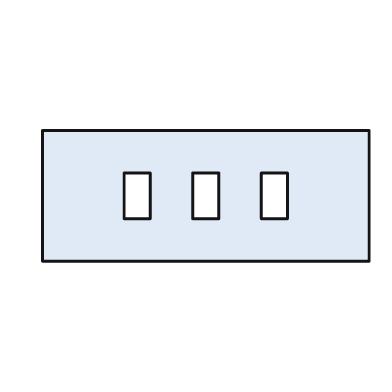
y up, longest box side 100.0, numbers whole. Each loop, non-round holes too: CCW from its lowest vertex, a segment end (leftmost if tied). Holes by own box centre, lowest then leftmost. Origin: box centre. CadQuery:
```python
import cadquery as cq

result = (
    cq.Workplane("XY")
    .moveTo(-50.0, -20.0)
    .lineTo(50.0, -20.0)
    .lineTo(50.0, 20.0)
    .lineTo(-50.0, 20.0)
    .close()
    .moveTo(-25.0, -7.0)
    .lineTo(-17.0, -7.0)
    .lineTo(-17.0, 7.0)
    .lineTo(-25.0, 7.0)
    .close()
    .moveTo(-4.0, -7.0)
    .lineTo(4.0, -7.0)
    .lineTo(4.0, 7.0)
    .lineTo(-4.0, 7.0)
    .close()
    .moveTo(17.0, -7.0)
    .lineTo(25.0, -7.0)
    .lineTo(25.0, 7.0)
    .lineTo(17.0, 7.0)
    .close()
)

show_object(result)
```